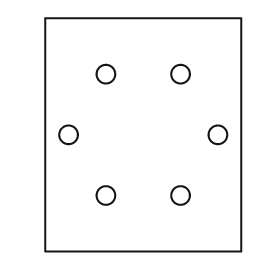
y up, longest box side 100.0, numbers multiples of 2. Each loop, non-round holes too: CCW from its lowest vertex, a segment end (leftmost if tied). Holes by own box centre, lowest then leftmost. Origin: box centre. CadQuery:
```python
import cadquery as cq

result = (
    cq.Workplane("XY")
    .moveTo(-42.0, -50.0)
    .lineTo(42.0, -50.0)
    .lineTo(42.0, 50.0)
    .lineTo(-42.0, 50.0)
    .close()
    .moveTo(-16.0, -26.0)
    .circle(4.0)
    .moveTo(16.0, -26.0)
    .circle(4.0)
    .moveTo(-32.0, 0.0)
    .circle(4.0)
    .moveTo(32.0, 0.0)
    .circle(4.0)
    .moveTo(-16.0, 26.0)
    .circle(4.0)
    .moveTo(16.0, 26.0)
    .circle(4.0)
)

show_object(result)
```